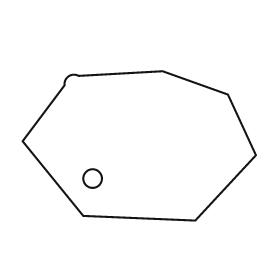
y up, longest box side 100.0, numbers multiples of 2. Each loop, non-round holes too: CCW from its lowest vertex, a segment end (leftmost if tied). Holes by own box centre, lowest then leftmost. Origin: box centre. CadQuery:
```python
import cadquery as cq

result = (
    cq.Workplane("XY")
    .moveTo(24.0, -32.0)
    .lineTo(50.0, -4.0)
    .lineTo(38.0, 22.0)
    .lineTo(10.0, 32.0)
    .lineTo(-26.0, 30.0)
    .threePointArc((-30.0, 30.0), (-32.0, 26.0))
    .lineTo(-50.0, 2.0)
    .lineTo(-24.0, -30.0)
    .close()
    .moveTo(-20.0, -14.0)
    .circle(4.0)
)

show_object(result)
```